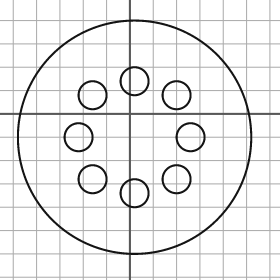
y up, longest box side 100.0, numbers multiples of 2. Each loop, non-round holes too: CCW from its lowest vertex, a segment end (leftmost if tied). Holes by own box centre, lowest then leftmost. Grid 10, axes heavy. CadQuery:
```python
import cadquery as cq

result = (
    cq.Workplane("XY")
    .moveTo(2.0, -10.0)
    .circle(50.0)
    .moveTo(2.0, -34.0)
    .circle(6.0)
    .moveTo(-16.0, -28.0)
    .circle(6.0)
    .moveTo(20.0, -28.0)
    .circle(6.0)
    .moveTo(-22.0, -10.0)
    .circle(6.0)
    .moveTo(26.0, -10.0)
    .circle(6.0)
    .moveTo(-16.0, 8.0)
    .circle(6.0)
    .moveTo(20.0, 8.0)
    .circle(6.0)
    .moveTo(2.0, 14.0)
    .circle(6.0)
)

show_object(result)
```